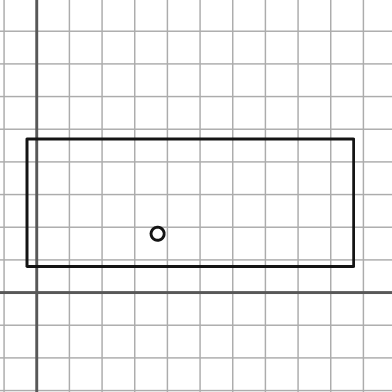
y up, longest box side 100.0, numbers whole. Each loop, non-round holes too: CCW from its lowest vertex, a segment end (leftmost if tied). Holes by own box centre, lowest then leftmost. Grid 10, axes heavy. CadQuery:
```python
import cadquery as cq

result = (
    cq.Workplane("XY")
    .moveTo(-3.0, 8.0)
    .lineTo(97.0, 8.0)
    .lineTo(97.0, 47.0)
    .lineTo(-3.0, 47.0)
    .close()
    .moveTo(37.0, 18.0)
    .circle(2.0)
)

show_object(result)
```